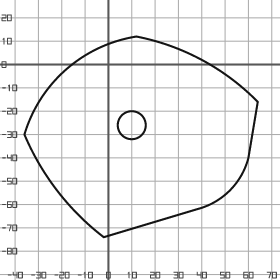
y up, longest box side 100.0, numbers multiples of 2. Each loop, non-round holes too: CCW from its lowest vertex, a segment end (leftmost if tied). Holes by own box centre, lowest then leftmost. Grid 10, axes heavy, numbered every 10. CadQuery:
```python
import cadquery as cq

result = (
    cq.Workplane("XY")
    .moveTo(-2.0, -74.0)
    .lineTo(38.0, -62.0)
    .threePointArc((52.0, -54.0), (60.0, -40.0))
    .lineTo(64.0, -16.0)
    .threePointArc((40.0, 2.0), (12.0, 12.0))
    .threePointArc((-18.0, -2.0), (-36.0, -30.0))
    .threePointArc((-22.0, -54.0), (-2.0, -74.0))
    .close()
    .moveTo(10.0, -26.0)
    .circle(6.0)
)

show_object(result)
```